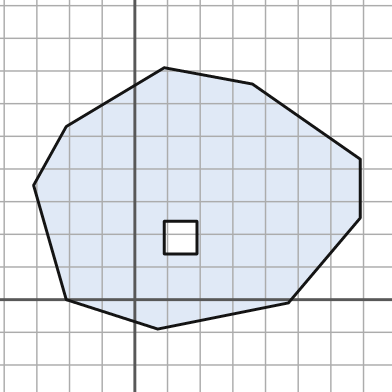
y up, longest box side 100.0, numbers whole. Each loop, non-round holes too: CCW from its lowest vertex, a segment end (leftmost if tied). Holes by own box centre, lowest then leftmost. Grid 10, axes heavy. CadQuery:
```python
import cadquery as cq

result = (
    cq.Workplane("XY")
    .moveTo(7.0, -9.0)
    .lineTo(47.0, -1.0)
    .lineTo(69.0, 25.0)
    .lineTo(69.0, 43.0)
    .lineTo(36.0, 66.0)
    .lineTo(9.0, 71.0)
    .lineTo(-21.0, 53.0)
    .lineTo(-31.0, 35.0)
    .lineTo(-21.0, 0.0)
    .close()
    .moveTo(9.0, 14.0)
    .lineTo(19.0, 14.0)
    .lineTo(19.0, 24.0)
    .lineTo(9.0, 24.0)
    .close()
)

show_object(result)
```